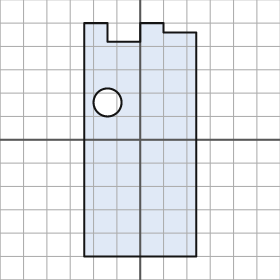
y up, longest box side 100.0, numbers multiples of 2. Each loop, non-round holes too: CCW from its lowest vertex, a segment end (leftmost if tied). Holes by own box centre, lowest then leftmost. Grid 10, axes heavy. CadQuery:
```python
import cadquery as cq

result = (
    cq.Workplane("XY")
    .moveTo(-24.0, -50.0)
    .lineTo(24.0, -50.0)
    .lineTo(24.0, 46.0)
    .lineTo(10.0, 46.0)
    .lineTo(10.0, 50.0)
    .lineTo(0.0, 50.0)
    .lineTo(0.0, 42.0)
    .lineTo(-14.0, 42.0)
    .lineTo(-14.0, 50.0)
    .lineTo(-24.0, 50.0)
    .close()
    .moveTo(-14.0, 16.0)
    .circle(6.0)
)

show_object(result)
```